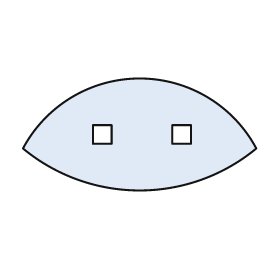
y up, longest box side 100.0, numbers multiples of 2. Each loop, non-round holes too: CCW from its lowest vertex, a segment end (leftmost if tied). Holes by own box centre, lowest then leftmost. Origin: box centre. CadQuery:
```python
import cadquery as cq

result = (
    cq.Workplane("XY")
    .moveTo(-50.0, -6.0)
    .threePointArc((0.0, -24.0), (50.0, -6.0))
    .threePointArc((0.0, 24.0), (-50.0, -6.0))
    .close()
    .moveTo(-20.0, -4.0)
    .lineTo(-12.0, -4.0)
    .lineTo(-12.0, 4.0)
    .lineTo(-20.0, 4.0)
    .close()
    .moveTo(14.0, -4.0)
    .lineTo(22.0, -4.0)
    .lineTo(22.0, 4.0)
    .lineTo(14.0, 4.0)
    .close()
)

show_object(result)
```